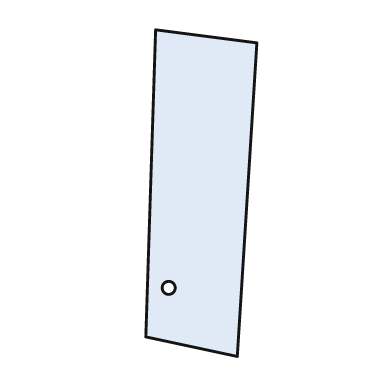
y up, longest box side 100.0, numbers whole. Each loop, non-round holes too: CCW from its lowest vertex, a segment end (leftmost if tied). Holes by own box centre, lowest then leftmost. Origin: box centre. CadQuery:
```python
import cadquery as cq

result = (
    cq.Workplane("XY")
    .moveTo(11.0, -50.0)
    .lineTo(17.0, 46.0)
    .lineTo(-14.0, 50.0)
    .lineTo(-17.0, -44.0)
    .close()
    .moveTo(-10.0, -29.0)
    .circle(2.0)
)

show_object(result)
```